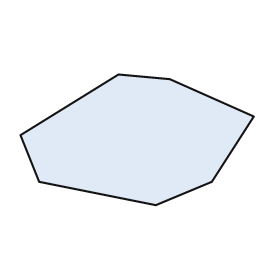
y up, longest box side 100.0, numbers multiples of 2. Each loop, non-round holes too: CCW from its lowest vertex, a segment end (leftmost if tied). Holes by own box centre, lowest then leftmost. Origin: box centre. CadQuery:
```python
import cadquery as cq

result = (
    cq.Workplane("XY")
    .moveTo(8.0, -28.0)
    .lineTo(32.0, -18.0)
    .lineTo(50.0, 10.0)
    .lineTo(14.0, 26.0)
    .lineTo(-8.0, 28.0)
    .lineTo(-50.0, 2.0)
    .lineTo(-42.0, -18.0)
    .close()
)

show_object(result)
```